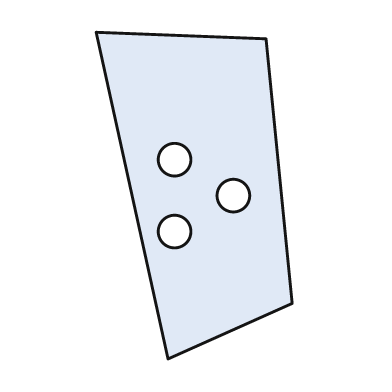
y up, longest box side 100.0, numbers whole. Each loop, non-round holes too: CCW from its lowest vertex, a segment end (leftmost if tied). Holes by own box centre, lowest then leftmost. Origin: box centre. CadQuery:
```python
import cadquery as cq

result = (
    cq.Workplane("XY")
    .moveTo(-8.0, -50.0)
    .lineTo(30.0, -33.0)
    .lineTo(22.0, 48.0)
    .lineTo(-30.0, 50.0)
    .close()
    .moveTo(-6.0, -11.0)
    .circle(5.0)
    .moveTo(12.0, 0.0)
    .circle(5.0)
    .moveTo(-6.0, 11.0)
    .circle(5.0)
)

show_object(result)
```